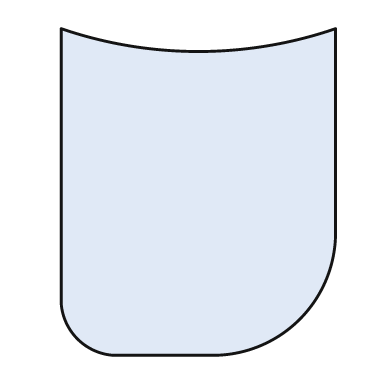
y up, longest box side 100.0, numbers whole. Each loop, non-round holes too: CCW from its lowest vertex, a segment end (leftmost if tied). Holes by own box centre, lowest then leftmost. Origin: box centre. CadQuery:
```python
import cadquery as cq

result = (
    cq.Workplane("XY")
    .moveTo(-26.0, -50.0)
    .lineTo(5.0, -50.0)
    .threePointArc((31.0, -39.0), (42.0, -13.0))
    .lineTo(42.0, 50.0)
    .threePointArc((0.0, 43.0), (-42.0, 50.0))
    .lineTo(-42.0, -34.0)
    .threePointArc((-37.0, -45.0), (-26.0, -50.0))
    .close()
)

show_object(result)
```